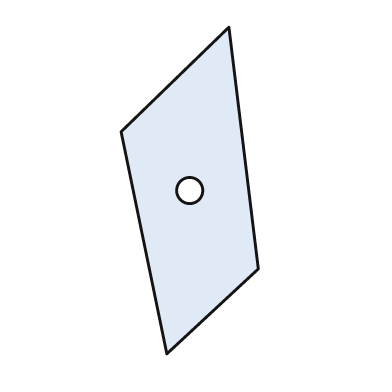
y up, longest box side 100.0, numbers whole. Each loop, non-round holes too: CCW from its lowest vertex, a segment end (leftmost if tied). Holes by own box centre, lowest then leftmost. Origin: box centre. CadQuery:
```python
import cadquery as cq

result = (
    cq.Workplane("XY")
    .moveTo(-7.0, -50.0)
    .lineTo(21.0, -24.0)
    .lineTo(12.0, 50.0)
    .lineTo(-21.0, 18.0)
    .close()
    .moveTo(0.0, 0.0)
    .circle(4.0)
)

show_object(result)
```